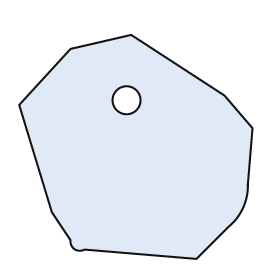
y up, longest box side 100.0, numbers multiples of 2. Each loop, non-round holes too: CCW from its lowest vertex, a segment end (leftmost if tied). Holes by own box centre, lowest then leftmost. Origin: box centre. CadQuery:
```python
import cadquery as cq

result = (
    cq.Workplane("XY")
    .moveTo(26.0, -48.0)
    .lineTo(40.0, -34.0)
    .threePointArc((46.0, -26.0), (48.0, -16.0))
    .lineTo(50.0, 8.0)
    .lineTo(38.0, 22.0)
    .lineTo(-2.0, 48.0)
    .lineTo(-28.0, 42.0)
    .lineTo(-50.0, 18.0)
    .lineTo(-36.0, -28.0)
    .lineTo(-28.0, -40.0)
    .threePointArc((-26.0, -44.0), (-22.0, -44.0))
    .close()
    .moveTo(-4.0, 20.0)
    .circle(6.0)
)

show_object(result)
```